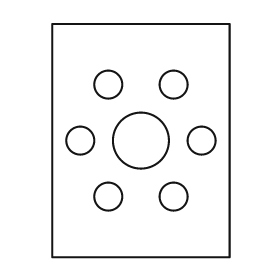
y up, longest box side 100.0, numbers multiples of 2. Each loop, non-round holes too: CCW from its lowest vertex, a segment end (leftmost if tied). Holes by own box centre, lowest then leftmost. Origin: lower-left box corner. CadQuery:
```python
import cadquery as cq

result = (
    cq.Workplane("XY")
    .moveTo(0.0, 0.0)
    .lineTo(76.0, 0.0)
    .lineTo(76.0, 100.0)
    .lineTo(0.0, 100.0)
    .close()
    .moveTo(24.0, 26.0)
    .circle(6.0)
    .moveTo(52.0, 26.0)
    .circle(6.0)
    .moveTo(12.0, 50.0)
    .circle(6.0)
    .moveTo(38.0, 50.0)
    .circle(12.0)
    .moveTo(64.0, 50.0)
    .circle(6.0)
    .moveTo(24.0, 74.0)
    .circle(6.0)
    .moveTo(52.0, 74.0)
    .circle(6.0)
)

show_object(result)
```